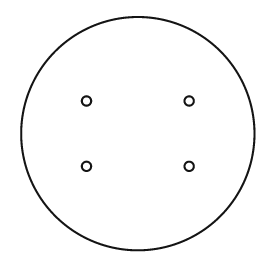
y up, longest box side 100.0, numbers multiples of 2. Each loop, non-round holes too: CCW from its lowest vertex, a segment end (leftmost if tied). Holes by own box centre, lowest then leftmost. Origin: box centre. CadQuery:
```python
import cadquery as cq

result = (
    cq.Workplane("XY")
    .moveTo(0.0, 0.0)
    .circle(50.0)
    .moveTo(-22.0, -14.0)
    .circle(2.0)
    .moveTo(22.0, -14.0)
    .circle(2.0)
    .moveTo(-22.0, 14.0)
    .circle(2.0)
    .moveTo(22.0, 14.0)
    .circle(2.0)
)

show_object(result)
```